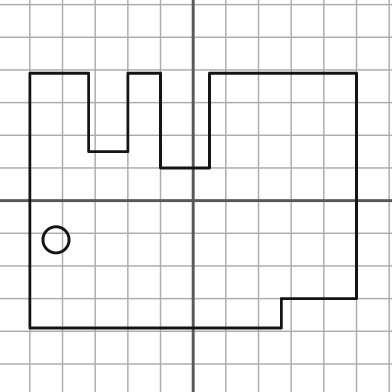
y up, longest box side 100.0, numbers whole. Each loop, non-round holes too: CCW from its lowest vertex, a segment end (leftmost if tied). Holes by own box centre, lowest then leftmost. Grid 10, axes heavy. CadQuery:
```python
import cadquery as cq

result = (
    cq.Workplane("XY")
    .moveTo(-50.0, -39.0)
    .lineTo(27.0, -39.0)
    .lineTo(27.0, -30.0)
    .lineTo(50.0, -30.0)
    .lineTo(50.0, 39.0)
    .lineTo(5.0, 39.0)
    .lineTo(5.0, 10.0)
    .lineTo(-10.0, 10.0)
    .lineTo(-10.0, 39.0)
    .lineTo(-20.0, 39.0)
    .lineTo(-20.0, 15.0)
    .lineTo(-32.0, 15.0)
    .lineTo(-32.0, 39.0)
    .lineTo(-50.0, 39.0)
    .close()
    .moveTo(-42.0, -12.0)
    .circle(4.0)
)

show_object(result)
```